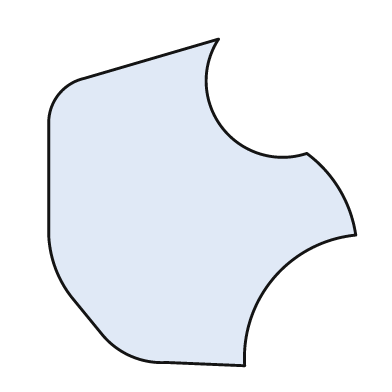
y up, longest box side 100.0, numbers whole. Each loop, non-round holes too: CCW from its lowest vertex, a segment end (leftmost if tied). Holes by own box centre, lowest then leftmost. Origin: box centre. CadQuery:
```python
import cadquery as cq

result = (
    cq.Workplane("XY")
    .moveTo(13.0, -50.0)
    .threePointArc((22.0, -23.0), (47.0, -10.0))
    .threePointArc((42.0, 4.0), (32.0, 15.0))
    .threePointArc((6.0, 23.0), (5.0, 50.0))
    .lineTo(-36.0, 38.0)
    .threePointArc((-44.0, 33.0), (-47.0, 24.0))
    .lineTo(-47.0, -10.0)
    .threePointArc((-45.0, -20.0), (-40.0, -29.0))
    .lineTo(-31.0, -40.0)
    .threePointArc((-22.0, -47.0), (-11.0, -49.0))
    .close()
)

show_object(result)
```